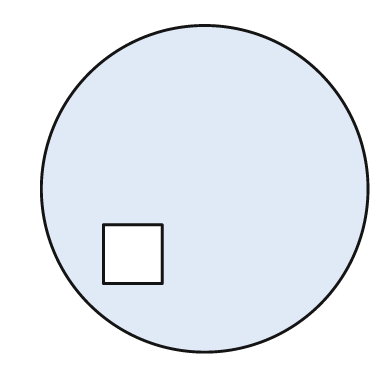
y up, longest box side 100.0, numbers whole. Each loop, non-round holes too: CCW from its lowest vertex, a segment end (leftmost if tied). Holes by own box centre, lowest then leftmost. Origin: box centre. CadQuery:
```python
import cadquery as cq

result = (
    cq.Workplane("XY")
    .moveTo(0.0, 0.0)
    .circle(50.0)
    .moveTo(-31.0, -29.0)
    .lineTo(-13.0, -29.0)
    .lineTo(-13.0, -11.0)
    .lineTo(-31.0, -11.0)
    .close()
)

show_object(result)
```